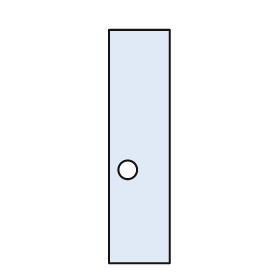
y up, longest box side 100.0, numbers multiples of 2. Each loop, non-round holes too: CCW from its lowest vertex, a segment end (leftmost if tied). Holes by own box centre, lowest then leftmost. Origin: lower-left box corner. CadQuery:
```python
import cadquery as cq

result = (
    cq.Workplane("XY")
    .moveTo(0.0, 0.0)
    .lineTo(26.0, 0.0)
    .lineTo(26.0, 100.0)
    .lineTo(0.0, 100.0)
    .close()
    .moveTo(8.0, 40.0)
    .circle(4.0)
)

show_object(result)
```